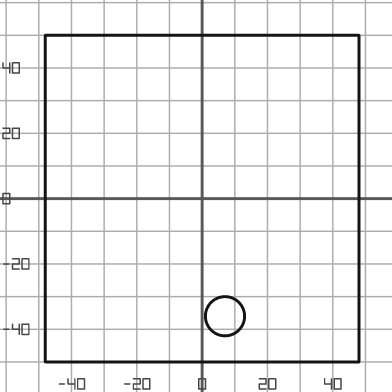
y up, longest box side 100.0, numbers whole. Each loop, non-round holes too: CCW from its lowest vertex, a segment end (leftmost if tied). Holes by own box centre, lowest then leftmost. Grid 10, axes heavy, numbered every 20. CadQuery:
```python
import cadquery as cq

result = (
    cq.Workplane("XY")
    .moveTo(-48.0, -50.0)
    .lineTo(48.0, -50.0)
    .lineTo(48.0, 50.0)
    .lineTo(-48.0, 50.0)
    .close()
    .moveTo(7.0, -36.0)
    .circle(6.0)
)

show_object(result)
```